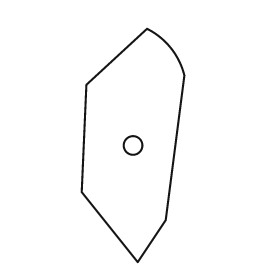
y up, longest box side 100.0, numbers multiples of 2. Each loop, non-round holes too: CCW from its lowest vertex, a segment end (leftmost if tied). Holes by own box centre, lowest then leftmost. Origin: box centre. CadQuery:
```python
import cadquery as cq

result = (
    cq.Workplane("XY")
    .moveTo(2.0, -50.0)
    .lineTo(14.0, -32.0)
    .lineTo(22.0, 30.0)
    .threePointArc((16.0, 42.0), (6.0, 50.0))
    .lineTo(-20.0, 26.0)
    .lineTo(-22.0, -20.0)
    .close()
    .moveTo(0.0, 0.0)
    .circle(4.0)
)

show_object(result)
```